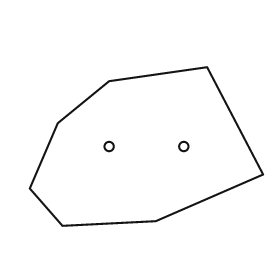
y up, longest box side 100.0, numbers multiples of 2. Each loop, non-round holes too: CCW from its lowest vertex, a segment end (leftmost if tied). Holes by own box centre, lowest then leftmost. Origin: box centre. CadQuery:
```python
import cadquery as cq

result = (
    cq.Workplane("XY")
    .moveTo(-36.0, -34.0)
    .lineTo(4.0, -32.0)
    .lineTo(50.0, -12.0)
    .lineTo(26.0, 34.0)
    .lineTo(-16.0, 28.0)
    .lineTo(-38.0, 10.0)
    .lineTo(-50.0, -18.0)
    .close()
    .moveTo(-16.0, 0.0)
    .circle(2.0)
    .moveTo(16.0, 0.0)
    .circle(2.0)
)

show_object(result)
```